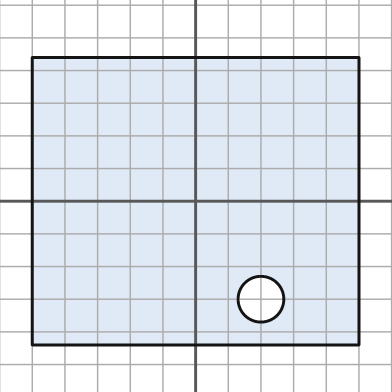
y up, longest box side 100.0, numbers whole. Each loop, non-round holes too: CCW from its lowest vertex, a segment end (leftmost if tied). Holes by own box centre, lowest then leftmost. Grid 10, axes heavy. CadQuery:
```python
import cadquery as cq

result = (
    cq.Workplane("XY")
    .moveTo(-50.0, -44.0)
    .lineTo(50.0, -44.0)
    .lineTo(50.0, 44.0)
    .lineTo(-50.0, 44.0)
    .close()
    .moveTo(20.0, -30.0)
    .circle(7.0)
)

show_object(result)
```